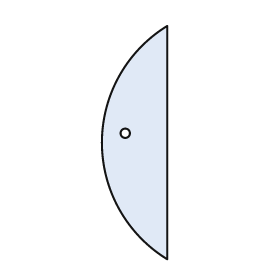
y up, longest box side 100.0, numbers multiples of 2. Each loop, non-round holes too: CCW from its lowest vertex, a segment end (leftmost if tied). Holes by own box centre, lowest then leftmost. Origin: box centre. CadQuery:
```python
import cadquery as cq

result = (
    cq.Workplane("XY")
    .moveTo(14.0, -50.0)
    .lineTo(14.0, 50.0)
    .threePointArc((-14.0, 0.0), (14.0, -50.0))
    .close()
    .moveTo(-4.0, 4.0)
    .circle(2.0)
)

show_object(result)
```